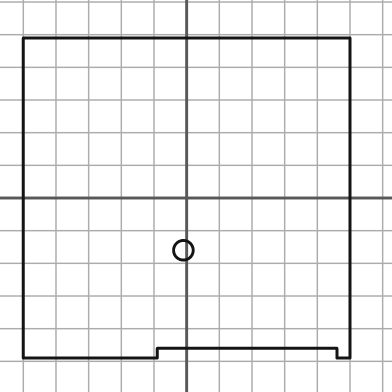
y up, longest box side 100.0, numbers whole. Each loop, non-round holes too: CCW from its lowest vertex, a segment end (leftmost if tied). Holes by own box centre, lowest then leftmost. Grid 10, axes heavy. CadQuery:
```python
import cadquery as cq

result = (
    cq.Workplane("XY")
    .moveTo(-50.0, -49.0)
    .lineTo(-9.0, -49.0)
    .lineTo(-9.0, -46.0)
    .lineTo(46.0, -46.0)
    .lineTo(46.0, -49.0)
    .lineTo(50.0, -49.0)
    .lineTo(50.0, 49.0)
    .lineTo(-50.0, 49.0)
    .close()
    .moveTo(-1.0, -16.0)
    .circle(3.0)
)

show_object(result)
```